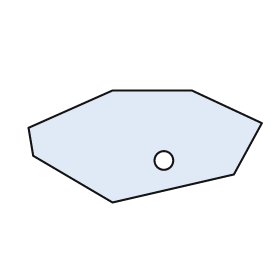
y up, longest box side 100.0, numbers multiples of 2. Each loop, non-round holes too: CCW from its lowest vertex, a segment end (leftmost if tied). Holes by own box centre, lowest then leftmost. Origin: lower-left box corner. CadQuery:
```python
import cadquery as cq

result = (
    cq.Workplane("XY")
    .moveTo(36.0, 0.0)
    .lineTo(88.0, 12.0)
    .lineTo(100.0, 34.0)
    .lineTo(70.0, 48.0)
    .lineTo(36.0, 48.0)
    .lineTo(0.0, 32.0)
    .lineTo(2.0, 20.0)
    .close()
    .moveTo(58.0, 18.0)
    .circle(4.0)
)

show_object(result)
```